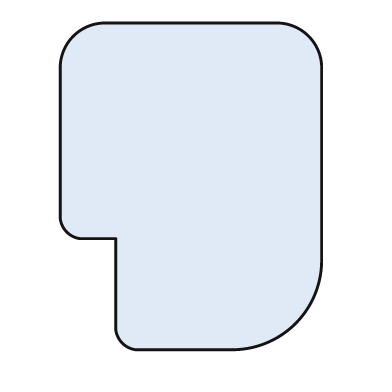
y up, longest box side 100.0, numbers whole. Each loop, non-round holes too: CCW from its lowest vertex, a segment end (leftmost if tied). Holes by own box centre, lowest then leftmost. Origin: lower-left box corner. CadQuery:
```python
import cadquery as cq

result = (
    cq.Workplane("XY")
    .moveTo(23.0, 0.0)
    .lineTo(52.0, 0.0)
    .threePointArc((72.0, 8.0), (80.0, 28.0))
    .lineTo(80.0, 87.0)
    .threePointArc((76.0, 96.0), (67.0, 100.0))
    .lineTo(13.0, 100.0)
    .threePointArc((4.0, 96.0), (0.0, 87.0))
    .lineTo(0.0, 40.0)
    .threePointArc((2.0, 36.0), (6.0, 34.0))
    .lineTo(17.0, 34.0)
    .lineTo(17.0, 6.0)
    .threePointArc((19.0, 2.0), (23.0, 0.0))
    .close()
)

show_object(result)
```